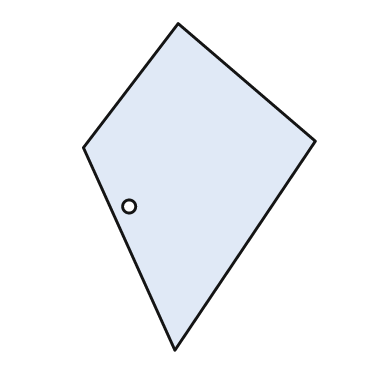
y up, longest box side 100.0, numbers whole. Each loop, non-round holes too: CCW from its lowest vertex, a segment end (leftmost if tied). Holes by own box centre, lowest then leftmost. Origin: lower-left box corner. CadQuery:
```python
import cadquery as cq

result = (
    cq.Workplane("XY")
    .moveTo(28.0, 0.0)
    .lineTo(71.0, 64.0)
    .lineTo(29.0, 100.0)
    .lineTo(0.0, 62.0)
    .close()
    .moveTo(14.0, 44.0)
    .circle(2.0)
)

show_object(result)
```